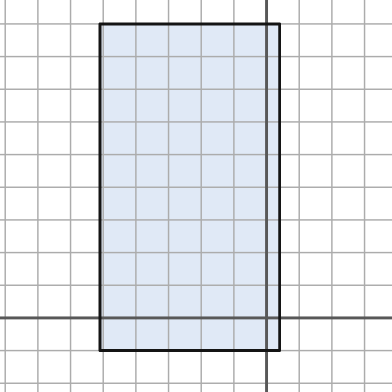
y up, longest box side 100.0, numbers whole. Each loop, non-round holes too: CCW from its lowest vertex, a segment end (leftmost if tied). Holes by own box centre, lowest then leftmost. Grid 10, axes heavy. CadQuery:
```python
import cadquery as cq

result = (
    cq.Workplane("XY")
    .moveTo(-51.0, -10.0)
    .lineTo(4.0, -10.0)
    .lineTo(4.0, 90.0)
    .lineTo(-51.0, 90.0)
    .close()
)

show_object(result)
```